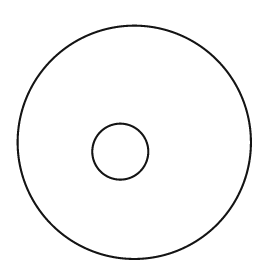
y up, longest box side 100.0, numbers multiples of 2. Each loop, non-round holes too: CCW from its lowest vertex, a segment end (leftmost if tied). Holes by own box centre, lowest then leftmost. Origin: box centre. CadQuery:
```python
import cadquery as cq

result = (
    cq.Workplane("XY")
    .moveTo(0.0, 0.0)
    .circle(50.0)
    .moveTo(-6.0, -4.0)
    .circle(12.0)
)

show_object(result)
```